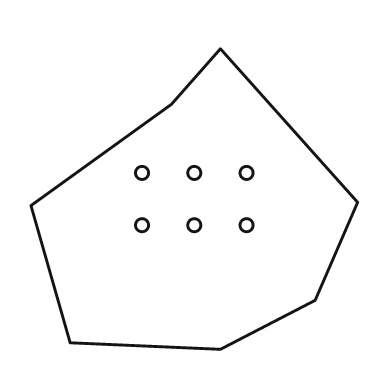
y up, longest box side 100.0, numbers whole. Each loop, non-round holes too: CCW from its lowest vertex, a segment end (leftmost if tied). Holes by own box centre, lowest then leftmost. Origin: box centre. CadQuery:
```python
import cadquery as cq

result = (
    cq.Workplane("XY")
    .moveTo(8.0, -46.0)
    .lineTo(37.0, -31.0)
    .lineTo(50.0, -1.0)
    .lineTo(8.0, 46.0)
    .lineTo(-7.0, 29.0)
    .lineTo(-50.0, -2.0)
    .lineTo(-38.0, -44.0)
    .close()
    .moveTo(-16.0, -8.0)
    .circle(2.0)
    .moveTo(0.0, -8.0)
    .circle(2.0)
    .moveTo(16.0, -8.0)
    .circle(2.0)
    .moveTo(-16.0, 8.0)
    .circle(2.0)
    .moveTo(0.0, 8.0)
    .circle(2.0)
    .moveTo(16.0, 8.0)
    .circle(2.0)
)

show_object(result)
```